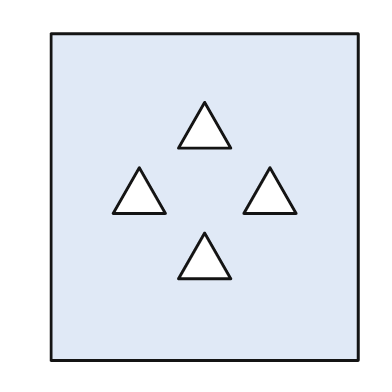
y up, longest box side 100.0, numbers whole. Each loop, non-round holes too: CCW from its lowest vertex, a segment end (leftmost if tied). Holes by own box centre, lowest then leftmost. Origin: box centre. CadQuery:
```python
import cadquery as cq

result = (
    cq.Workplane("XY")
    .moveTo(-47.0, -50.0)
    .lineTo(47.0, -50.0)
    .lineTo(47.0, 50.0)
    .lineTo(-47.0, 50.0)
    .close()
    .moveTo(-8.0, -25.0)
    .lineTo(8.0, -25.0)
    .lineTo(0.0, -11.0)
    .close()
    .moveTo(-28.0, -5.0)
    .lineTo(-12.0, -5.0)
    .lineTo(-20.0, 9.0)
    .close()
    .moveTo(12.0, -5.0)
    .lineTo(28.0, -5.0)
    .lineTo(20.0, 9.0)
    .close()
    .moveTo(-8.0, 15.0)
    .lineTo(8.0, 15.0)
    .lineTo(0.0, 29.0)
    .close()
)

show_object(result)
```